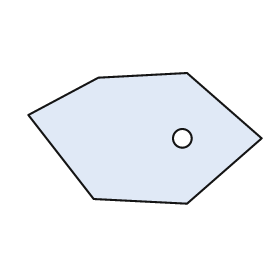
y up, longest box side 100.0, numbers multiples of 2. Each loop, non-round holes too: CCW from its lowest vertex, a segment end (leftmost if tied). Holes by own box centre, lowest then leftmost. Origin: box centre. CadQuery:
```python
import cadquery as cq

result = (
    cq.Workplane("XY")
    .moveTo(18.0, -28.0)
    .lineTo(50.0, 0.0)
    .lineTo(18.0, 28.0)
    .lineTo(-20.0, 26.0)
    .lineTo(-50.0, 10.0)
    .lineTo(-22.0, -26.0)
    .close()
    .moveTo(16.0, 0.0)
    .circle(4.0)
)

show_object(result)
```